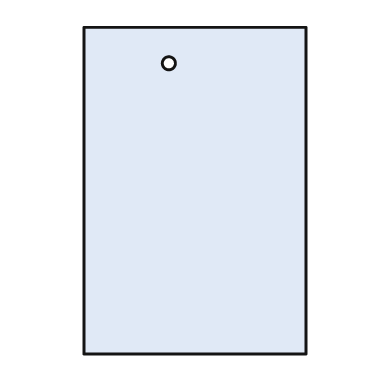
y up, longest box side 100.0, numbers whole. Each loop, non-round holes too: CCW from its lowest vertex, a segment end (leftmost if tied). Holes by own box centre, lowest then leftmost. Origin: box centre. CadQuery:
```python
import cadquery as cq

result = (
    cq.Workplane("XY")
    .moveTo(-34.0, -50.0)
    .lineTo(34.0, -50.0)
    .lineTo(34.0, 50.0)
    .lineTo(-34.0, 50.0)
    .close()
    .moveTo(-8.0, 39.0)
    .circle(2.0)
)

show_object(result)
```